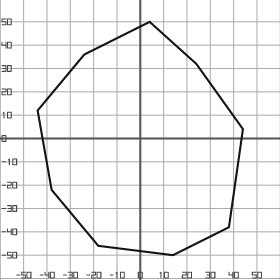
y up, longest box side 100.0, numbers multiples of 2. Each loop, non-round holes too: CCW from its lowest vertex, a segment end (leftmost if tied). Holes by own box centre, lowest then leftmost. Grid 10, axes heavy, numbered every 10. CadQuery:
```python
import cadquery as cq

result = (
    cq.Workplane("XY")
    .moveTo(14.0, -50.0)
    .lineTo(38.0, -38.0)
    .lineTo(44.0, 4.0)
    .lineTo(24.0, 32.0)
    .lineTo(4.0, 50.0)
    .lineTo(-24.0, 36.0)
    .lineTo(-44.0, 12.0)
    .lineTo(-38.0, -22.0)
    .lineTo(-18.0, -46.0)
    .close()
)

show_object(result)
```